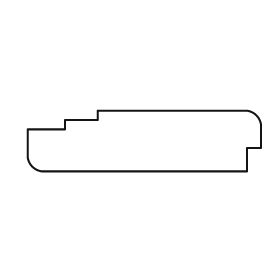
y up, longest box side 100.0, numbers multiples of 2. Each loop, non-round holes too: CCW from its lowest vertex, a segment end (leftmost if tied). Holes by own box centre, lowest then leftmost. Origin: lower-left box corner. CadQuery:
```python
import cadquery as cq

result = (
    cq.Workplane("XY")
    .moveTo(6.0, 0.0)
    .lineTo(94.0, 0.0)
    .lineTo(94.0, 10.0)
    .lineTo(100.0, 10.0)
    .lineTo(100.0, 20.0)
    .threePointArc((98.0, 24.0), (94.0, 26.0))
    .lineTo(30.0, 26.0)
    .lineTo(30.0, 22.0)
    .lineTo(16.0, 22.0)
    .lineTo(16.0, 18.0)
    .lineTo(0.0, 18.0)
    .lineTo(0.0, 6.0)
    .threePointArc((2.0, 2.0), (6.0, 0.0))
    .close()
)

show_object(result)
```